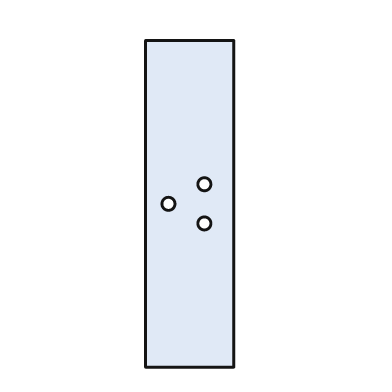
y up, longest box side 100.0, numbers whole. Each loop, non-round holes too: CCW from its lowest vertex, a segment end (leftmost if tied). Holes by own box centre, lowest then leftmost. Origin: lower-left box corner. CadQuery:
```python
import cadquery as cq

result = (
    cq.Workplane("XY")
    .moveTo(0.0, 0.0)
    .lineTo(27.0, 0.0)
    .lineTo(27.0, 100.0)
    .lineTo(0.0, 100.0)
    .close()
    .moveTo(18.0, 44.0)
    .circle(2.0)
    .moveTo(7.0, 50.0)
    .circle(2.0)
    .moveTo(18.0, 56.0)
    .circle(2.0)
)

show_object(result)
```